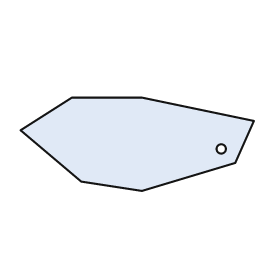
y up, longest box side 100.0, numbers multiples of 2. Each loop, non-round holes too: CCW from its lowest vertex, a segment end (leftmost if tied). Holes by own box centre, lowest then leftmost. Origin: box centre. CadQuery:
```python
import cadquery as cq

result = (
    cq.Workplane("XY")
    .moveTo(2.0, -20.0)
    .lineTo(42.0, -8.0)
    .lineTo(50.0, 10.0)
    .lineTo(2.0, 20.0)
    .lineTo(-28.0, 20.0)
    .lineTo(-50.0, 6.0)
    .lineTo(-24.0, -16.0)
    .close()
    .moveTo(36.0, -2.0)
    .circle(2.0)
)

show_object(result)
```